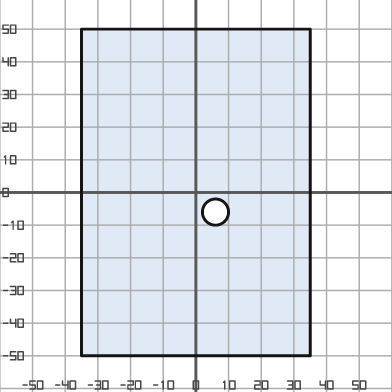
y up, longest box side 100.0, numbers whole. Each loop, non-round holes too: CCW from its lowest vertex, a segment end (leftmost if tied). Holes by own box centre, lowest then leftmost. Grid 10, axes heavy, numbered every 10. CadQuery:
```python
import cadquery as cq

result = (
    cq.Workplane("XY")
    .moveTo(-35.0, -50.0)
    .lineTo(35.0, -50.0)
    .lineTo(35.0, 50.0)
    .lineTo(-35.0, 50.0)
    .close()
    .moveTo(6.0, -6.0)
    .circle(4.0)
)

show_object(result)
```